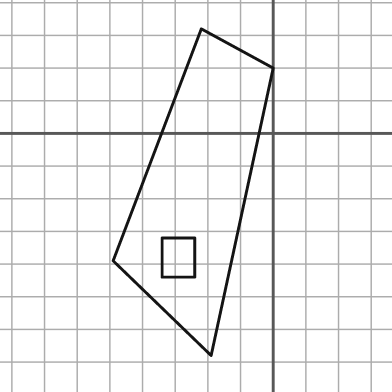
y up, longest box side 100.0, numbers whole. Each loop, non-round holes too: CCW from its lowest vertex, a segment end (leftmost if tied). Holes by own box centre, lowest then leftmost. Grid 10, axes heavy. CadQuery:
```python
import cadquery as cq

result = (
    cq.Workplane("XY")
    .moveTo(-19.0, -68.0)
    .lineTo(0.0, 20.0)
    .lineTo(-22.0, 32.0)
    .lineTo(-49.0, -39.0)
    .close()
    .moveTo(-34.0, -44.0)
    .lineTo(-24.0, -44.0)
    .lineTo(-24.0, -32.0)
    .lineTo(-34.0, -32.0)
    .close()
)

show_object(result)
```